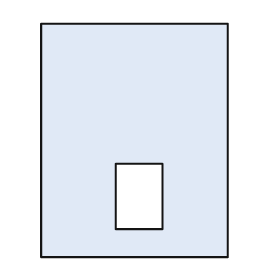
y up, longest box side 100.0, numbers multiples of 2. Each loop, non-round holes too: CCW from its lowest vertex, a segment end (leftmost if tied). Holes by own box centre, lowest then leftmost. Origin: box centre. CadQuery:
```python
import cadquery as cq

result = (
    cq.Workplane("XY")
    .moveTo(-40.0, -50.0)
    .lineTo(40.0, -50.0)
    .lineTo(40.0, 50.0)
    .lineTo(-40.0, 50.0)
    .close()
    .moveTo(-8.0, -38.0)
    .lineTo(12.0, -38.0)
    .lineTo(12.0, -10.0)
    .lineTo(-8.0, -10.0)
    .close()
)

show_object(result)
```